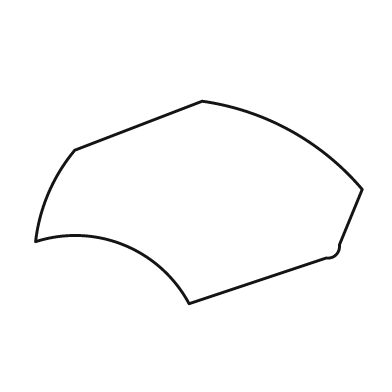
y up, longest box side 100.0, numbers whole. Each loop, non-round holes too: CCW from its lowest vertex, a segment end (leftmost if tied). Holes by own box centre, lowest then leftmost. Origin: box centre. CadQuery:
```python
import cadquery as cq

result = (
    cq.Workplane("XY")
    .moveTo(-3.0, -31.0)
    .lineTo(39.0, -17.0)
    .threePointArc((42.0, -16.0), (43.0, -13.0))
    .lineTo(50.0, 4.0)
    .threePointArc((28.0, 22.0), (1.0, 31.0))
    .lineTo(-38.0, 16.0)
    .threePointArc((-46.0, 3.0), (-50.0, -12.0))
    .threePointArc((-23.0, -13.0), (-3.0, -31.0))
    .close()
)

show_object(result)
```